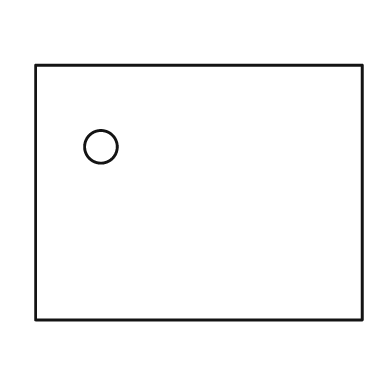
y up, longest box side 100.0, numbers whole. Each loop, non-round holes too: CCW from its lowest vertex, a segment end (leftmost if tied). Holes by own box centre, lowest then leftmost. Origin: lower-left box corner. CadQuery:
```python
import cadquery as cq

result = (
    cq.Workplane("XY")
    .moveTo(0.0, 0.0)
    .lineTo(100.0, 0.0)
    .lineTo(100.0, 78.0)
    .lineTo(0.0, 78.0)
    .close()
    .moveTo(20.0, 53.0)
    .circle(5.0)
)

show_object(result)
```